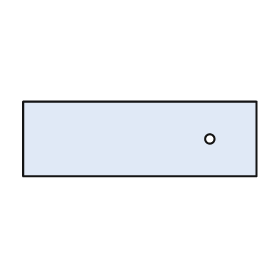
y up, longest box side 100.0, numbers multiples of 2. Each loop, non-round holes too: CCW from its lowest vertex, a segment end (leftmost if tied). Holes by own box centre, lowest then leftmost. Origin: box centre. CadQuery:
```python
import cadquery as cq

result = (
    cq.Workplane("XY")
    .moveTo(-50.0, -16.0)
    .lineTo(50.0, -16.0)
    .lineTo(50.0, 16.0)
    .lineTo(-50.0, 16.0)
    .close()
    .moveTo(30.0, 0.0)
    .circle(2.0)
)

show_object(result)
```